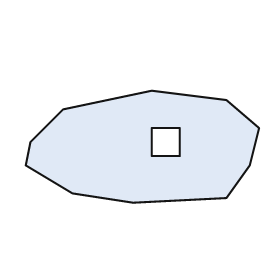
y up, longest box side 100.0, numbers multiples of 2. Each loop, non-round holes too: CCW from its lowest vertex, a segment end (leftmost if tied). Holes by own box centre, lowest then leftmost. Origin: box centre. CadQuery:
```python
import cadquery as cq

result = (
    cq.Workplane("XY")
    .moveTo(-4.0, -24.0)
    .lineTo(36.0, -22.0)
    .lineTo(46.0, -8.0)
    .lineTo(50.0, 8.0)
    .lineTo(36.0, 20.0)
    .lineTo(4.0, 24.0)
    .lineTo(-34.0, 16.0)
    .lineTo(-48.0, 2.0)
    .lineTo(-50.0, -8.0)
    .lineTo(-30.0, -20.0)
    .close()
    .moveTo(4.0, -4.0)
    .lineTo(16.0, -4.0)
    .lineTo(16.0, 8.0)
    .lineTo(4.0, 8.0)
    .close()
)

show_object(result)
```